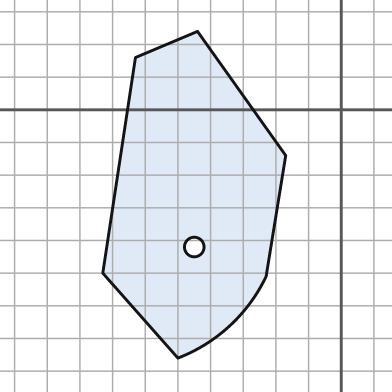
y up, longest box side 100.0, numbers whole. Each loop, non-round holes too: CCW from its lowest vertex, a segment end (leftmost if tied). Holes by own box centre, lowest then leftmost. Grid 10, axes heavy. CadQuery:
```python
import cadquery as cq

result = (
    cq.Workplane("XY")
    .moveTo(-50.0, -76.0)
    .threePointArc((-34.0, -66.0), (-23.0, -51.0))
    .lineTo(-17.0, -14.0)
    .lineTo(-44.0, 24.0)
    .lineTo(-63.0, 16.0)
    .lineTo(-73.0, -50.0)
    .close()
    .moveTo(-45.0, -42.0)
    .circle(3.0)
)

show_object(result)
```